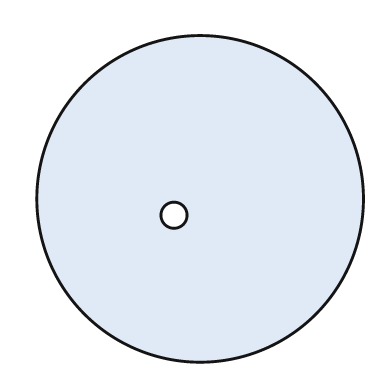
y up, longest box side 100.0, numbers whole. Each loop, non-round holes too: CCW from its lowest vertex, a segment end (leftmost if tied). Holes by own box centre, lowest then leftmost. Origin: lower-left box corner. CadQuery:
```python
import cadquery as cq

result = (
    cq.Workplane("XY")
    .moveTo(50.0, 50.0)
    .circle(50.0)
    .moveTo(42.0, 45.0)
    .circle(4.0)
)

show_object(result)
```